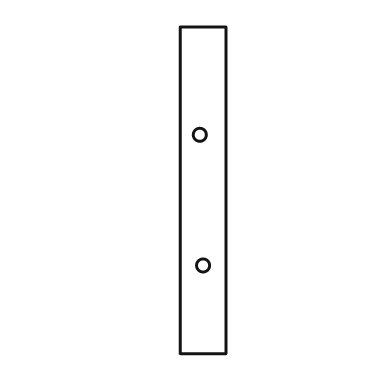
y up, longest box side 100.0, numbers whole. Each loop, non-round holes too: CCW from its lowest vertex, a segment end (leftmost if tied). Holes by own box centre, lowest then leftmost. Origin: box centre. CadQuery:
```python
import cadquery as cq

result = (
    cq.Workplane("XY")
    .moveTo(-7.0, -50.0)
    .lineTo(7.0, -50.0)
    .lineTo(7.0, 50.0)
    .lineTo(-7.0, 50.0)
    .close()
    .moveTo(0.0, -23.0)
    .circle(2.0)
    .moveTo(-1.0, 17.0)
    .circle(2.0)
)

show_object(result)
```